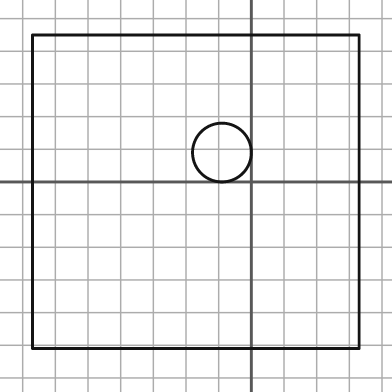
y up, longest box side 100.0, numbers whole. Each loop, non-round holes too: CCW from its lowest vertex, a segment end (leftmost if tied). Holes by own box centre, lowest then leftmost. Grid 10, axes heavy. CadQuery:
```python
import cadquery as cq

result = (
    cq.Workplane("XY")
    .moveTo(-67.0, -51.0)
    .lineTo(33.0, -51.0)
    .lineTo(33.0, 45.0)
    .lineTo(-67.0, 45.0)
    .close()
    .moveTo(-9.0, 9.0)
    .circle(9.0)
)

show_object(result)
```